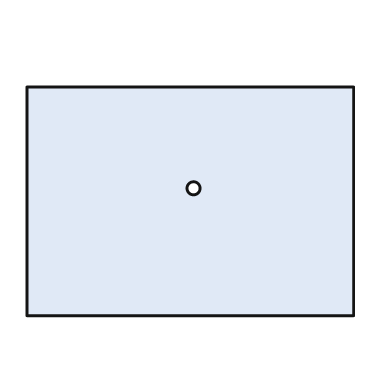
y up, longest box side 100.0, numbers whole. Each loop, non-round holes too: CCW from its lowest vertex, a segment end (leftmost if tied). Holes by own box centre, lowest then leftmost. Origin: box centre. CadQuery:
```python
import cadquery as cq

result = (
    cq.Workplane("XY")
    .moveTo(-50.0, -35.0)
    .lineTo(50.0, -35.0)
    .lineTo(50.0, 35.0)
    .lineTo(-50.0, 35.0)
    .close()
    .moveTo(1.0, 4.0)
    .circle(2.0)
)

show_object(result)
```